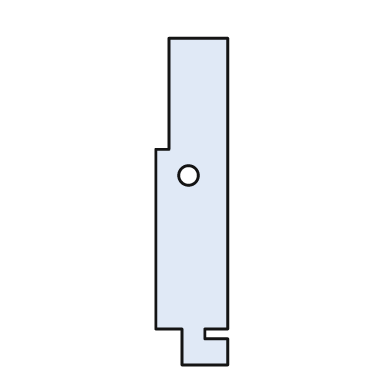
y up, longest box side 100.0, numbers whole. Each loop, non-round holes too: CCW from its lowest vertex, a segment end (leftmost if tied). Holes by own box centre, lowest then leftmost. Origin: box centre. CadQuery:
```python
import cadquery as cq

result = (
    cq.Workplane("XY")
    .moveTo(-3.0, -50.0)
    .lineTo(11.0, -50.0)
    .lineTo(11.0, -42.0)
    .lineTo(4.0, -42.0)
    .lineTo(4.0, -39.0)
    .lineTo(11.0, -39.0)
    .lineTo(11.0, 50.0)
    .lineTo(-7.0, 50.0)
    .lineTo(-7.0, 16.0)
    .lineTo(-11.0, 16.0)
    .lineTo(-11.0, -39.0)
    .lineTo(-3.0, -39.0)
    .close()
    .moveTo(-1.0, 8.0)
    .circle(3.0)
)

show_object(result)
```